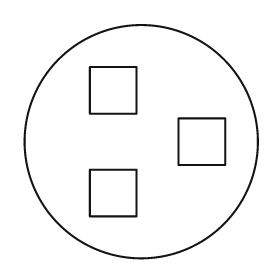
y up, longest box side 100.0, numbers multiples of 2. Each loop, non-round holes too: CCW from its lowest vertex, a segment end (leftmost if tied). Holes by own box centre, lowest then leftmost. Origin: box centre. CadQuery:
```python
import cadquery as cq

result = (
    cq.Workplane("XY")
    .moveTo(0.0, 0.0)
    .circle(50.0)
    .moveTo(-22.0, -32.0)
    .lineTo(-2.0, -32.0)
    .lineTo(-2.0, -12.0)
    .lineTo(-22.0, -12.0)
    .close()
    .moveTo(16.0, -10.0)
    .lineTo(36.0, -10.0)
    .lineTo(36.0, 10.0)
    .lineTo(16.0, 10.0)
    .close()
    .moveTo(-22.0, 12.0)
    .lineTo(-2.0, 12.0)
    .lineTo(-2.0, 32.0)
    .lineTo(-22.0, 32.0)
    .close()
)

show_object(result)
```